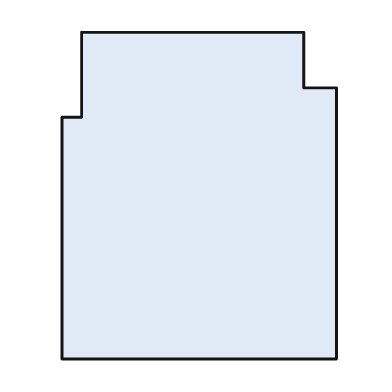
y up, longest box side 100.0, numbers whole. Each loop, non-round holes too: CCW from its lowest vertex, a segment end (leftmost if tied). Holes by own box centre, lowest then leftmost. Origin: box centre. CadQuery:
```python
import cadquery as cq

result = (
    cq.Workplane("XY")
    .moveTo(-42.0, -50.0)
    .lineTo(42.0, -50.0)
    .lineTo(42.0, 33.0)
    .lineTo(32.0, 33.0)
    .lineTo(32.0, 50.0)
    .lineTo(-36.0, 50.0)
    .lineTo(-36.0, 24.0)
    .lineTo(-42.0, 24.0)
    .close()
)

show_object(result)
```